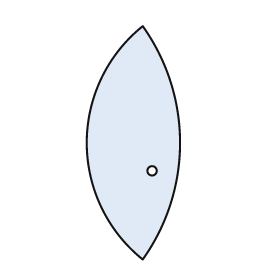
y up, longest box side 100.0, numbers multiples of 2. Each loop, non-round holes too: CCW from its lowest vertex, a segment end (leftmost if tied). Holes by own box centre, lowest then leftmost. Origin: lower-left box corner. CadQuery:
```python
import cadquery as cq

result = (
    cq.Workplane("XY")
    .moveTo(24.0, 0.0)
    .threePointArc((40.0, 50.0), (24.0, 100.0))
    .threePointArc((0.0, 50.0), (24.0, 0.0))
    .close()
    .moveTo(28.0, 38.0)
    .circle(2.0)
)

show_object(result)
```